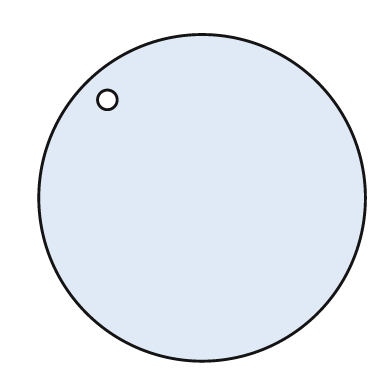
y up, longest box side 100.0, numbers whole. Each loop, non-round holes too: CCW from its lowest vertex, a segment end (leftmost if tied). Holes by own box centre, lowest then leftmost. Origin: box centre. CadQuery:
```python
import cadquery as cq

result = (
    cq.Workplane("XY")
    .moveTo(0.0, 0.0)
    .circle(50.0)
    .moveTo(-29.0, 30.0)
    .circle(3.0)
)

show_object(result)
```